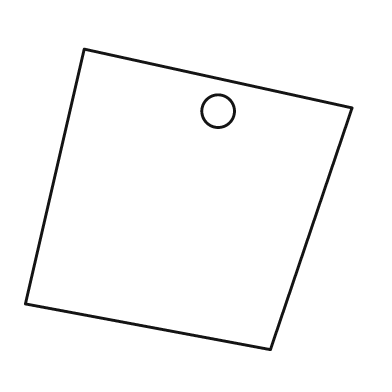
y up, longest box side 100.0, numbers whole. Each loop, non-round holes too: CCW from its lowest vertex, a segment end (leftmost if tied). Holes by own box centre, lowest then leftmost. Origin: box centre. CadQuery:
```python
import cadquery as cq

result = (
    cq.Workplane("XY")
    .moveTo(25.0, -46.0)
    .lineTo(50.0, 28.0)
    .lineTo(-32.0, 46.0)
    .lineTo(-50.0, -32.0)
    .close()
    .moveTo(9.0, 27.0)
    .circle(5.0)
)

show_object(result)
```